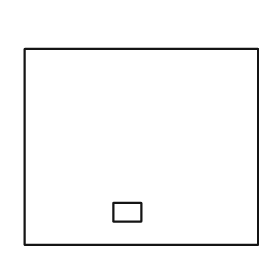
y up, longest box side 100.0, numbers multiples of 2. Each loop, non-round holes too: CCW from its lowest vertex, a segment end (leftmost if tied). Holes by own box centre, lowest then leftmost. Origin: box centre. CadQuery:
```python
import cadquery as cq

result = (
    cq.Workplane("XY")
    .moveTo(-50.0, -42.0)
    .lineTo(50.0, -42.0)
    .lineTo(50.0, 42.0)
    .lineTo(-50.0, 42.0)
    .close()
    .moveTo(-12.0, -32.0)
    .lineTo(0.0, -32.0)
    .lineTo(0.0, -24.0)
    .lineTo(-12.0, -24.0)
    .close()
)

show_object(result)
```